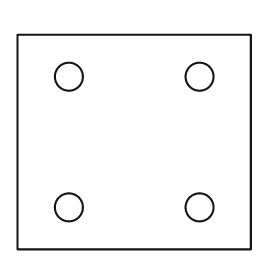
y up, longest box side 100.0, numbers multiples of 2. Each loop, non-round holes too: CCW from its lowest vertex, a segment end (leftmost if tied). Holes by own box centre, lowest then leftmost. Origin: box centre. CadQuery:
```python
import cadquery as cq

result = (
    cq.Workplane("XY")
    .moveTo(-50.0, -46.0)
    .lineTo(50.0, -46.0)
    .lineTo(50.0, 46.0)
    .lineTo(-50.0, 46.0)
    .close()
    .moveTo(-28.0, -28.0)
    .circle(6.0)
    .moveTo(28.0, -28.0)
    .circle(6.0)
    .moveTo(-28.0, 28.0)
    .circle(6.0)
    .moveTo(28.0, 28.0)
    .circle(6.0)
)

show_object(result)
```